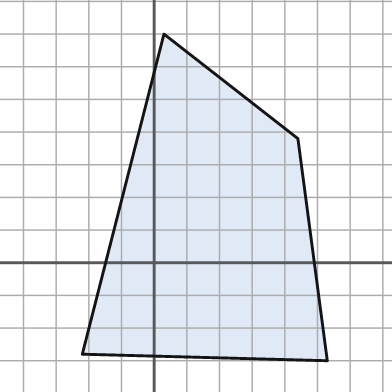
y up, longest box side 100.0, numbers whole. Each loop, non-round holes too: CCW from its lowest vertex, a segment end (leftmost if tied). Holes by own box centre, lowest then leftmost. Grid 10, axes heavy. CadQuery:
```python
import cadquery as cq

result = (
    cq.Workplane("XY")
    .moveTo(53.0, -30.0)
    .lineTo(44.0, 38.0)
    .lineTo(3.0, 70.0)
    .lineTo(-22.0, -28.0)
    .close()
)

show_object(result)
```